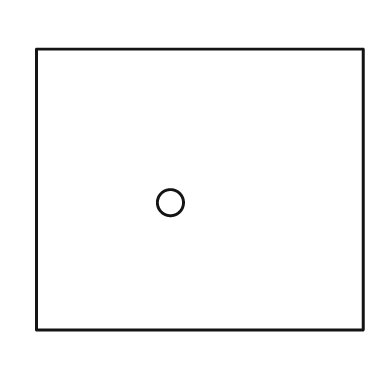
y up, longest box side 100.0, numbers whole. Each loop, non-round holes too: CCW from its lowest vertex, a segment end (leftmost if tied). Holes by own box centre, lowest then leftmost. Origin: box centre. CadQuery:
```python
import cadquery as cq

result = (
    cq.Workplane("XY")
    .moveTo(-50.0, -43.0)
    .lineTo(50.0, -43.0)
    .lineTo(50.0, 43.0)
    .lineTo(-50.0, 43.0)
    .close()
    .moveTo(-9.0, -4.0)
    .circle(4.0)
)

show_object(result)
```